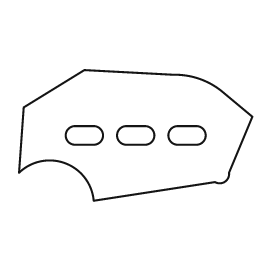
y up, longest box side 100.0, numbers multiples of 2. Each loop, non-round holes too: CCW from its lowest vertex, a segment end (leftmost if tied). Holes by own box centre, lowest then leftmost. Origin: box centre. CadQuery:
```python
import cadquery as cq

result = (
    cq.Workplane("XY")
    .moveTo(-18.0, -28.0)
    .lineTo(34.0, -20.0)
    .threePointArc((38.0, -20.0), (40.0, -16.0))
    .lineTo(50.0, 8.0)
    .lineTo(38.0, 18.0)
    .threePointArc((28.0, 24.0), (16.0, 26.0))
    .lineTo(-22.0, 28.0)
    .lineTo(-48.0, 12.0)
    .lineTo(-50.0, -16.0)
    .threePointArc((-30.0, -12.0), (-18.0, -28.0))
    .close()
    .moveTo(-26.0, -4.0)
    .lineTo(-18.0, -4.0)
    .threePointArc((-14.0, 0.0), (-18.0, 4.0))
    .lineTo(-26.0, 4.0)
    .threePointArc((-30.0, 0.0), (-26.0, -4.0))
    .close()
    .moveTo(-4.0, -4.0)
    .lineTo(4.0, -4.0)
    .threePointArc((8.0, 0.0), (4.0, 4.0))
    .lineTo(-4.0, 4.0)
    .threePointArc((-8.0, 0.0), (-4.0, -4.0))
    .close()
    .moveTo(18.0, -4.0)
    .lineTo(26.0, -4.0)
    .threePointArc((30.0, 0.0), (26.0, 4.0))
    .lineTo(18.0, 4.0)
    .threePointArc((14.0, 0.0), (18.0, -4.0))
    .close()
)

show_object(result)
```